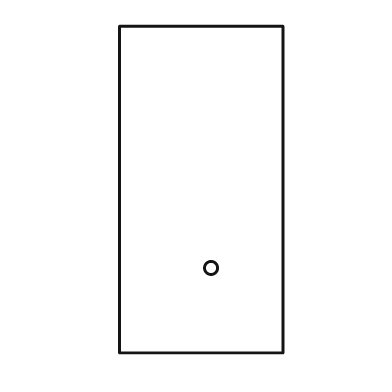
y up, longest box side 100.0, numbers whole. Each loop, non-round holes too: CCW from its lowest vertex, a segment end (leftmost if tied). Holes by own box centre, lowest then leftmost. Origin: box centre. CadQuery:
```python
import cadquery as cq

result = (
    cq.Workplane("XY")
    .moveTo(-25.0, -50.0)
    .lineTo(25.0, -50.0)
    .lineTo(25.0, 50.0)
    .lineTo(-25.0, 50.0)
    .close()
    .moveTo(3.0, -24.0)
    .circle(2.0)
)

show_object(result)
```